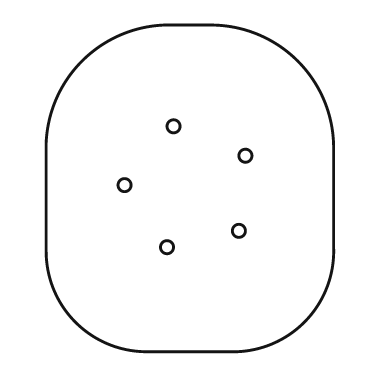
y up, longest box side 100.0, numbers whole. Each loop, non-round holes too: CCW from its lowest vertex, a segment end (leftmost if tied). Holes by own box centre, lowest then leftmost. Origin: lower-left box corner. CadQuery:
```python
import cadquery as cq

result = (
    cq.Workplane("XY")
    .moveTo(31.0, 0.0)
    .lineTo(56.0, 0.0)
    .threePointArc((79.0, 9.0), (88.0, 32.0))
    .lineTo(88.0, 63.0)
    .threePointArc((77.0, 89.0), (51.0, 100.0))
    .lineTo(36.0, 100.0)
    .threePointArc((11.0, 89.0), (0.0, 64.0))
    .lineTo(0.0, 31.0)
    .threePointArc((9.0, 9.0), (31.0, 0.0))
    .close()
    .moveTo(37.0, 32.0)
    .circle(2.0)
    .moveTo(59.0, 37.0)
    .circle(2.0)
    .moveTo(24.0, 51.0)
    .circle(2.0)
    .moveTo(61.0, 60.0)
    .circle(2.0)
    .moveTo(39.0, 69.0)
    .circle(2.0)
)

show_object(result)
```